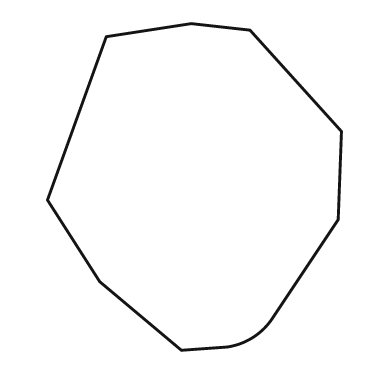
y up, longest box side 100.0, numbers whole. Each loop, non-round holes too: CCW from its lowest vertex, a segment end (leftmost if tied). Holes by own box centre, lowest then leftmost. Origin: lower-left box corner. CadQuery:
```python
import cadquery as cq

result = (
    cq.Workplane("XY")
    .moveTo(41.0, 0.0)
    .lineTo(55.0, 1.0)
    .threePointArc((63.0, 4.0), (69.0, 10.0))
    .lineTo(89.0, 40.0)
    .lineTo(90.0, 67.0)
    .lineTo(62.0, 98.0)
    .lineTo(44.0, 100.0)
    .lineTo(18.0, 96.0)
    .lineTo(0.0, 46.0)
    .lineTo(16.0, 21.0)
    .close()
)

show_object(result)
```